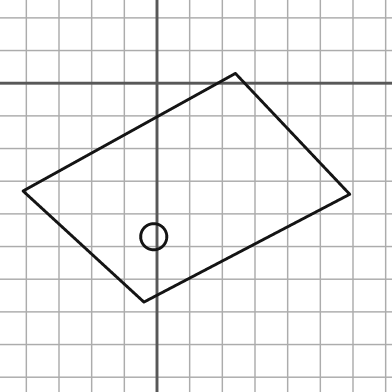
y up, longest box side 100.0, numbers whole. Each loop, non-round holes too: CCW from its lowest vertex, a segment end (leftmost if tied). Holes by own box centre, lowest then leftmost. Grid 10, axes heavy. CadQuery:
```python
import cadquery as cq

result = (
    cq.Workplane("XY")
    .moveTo(-4.0, -67.0)
    .lineTo(59.0, -34.0)
    .lineTo(24.0, 3.0)
    .lineTo(-41.0, -33.0)
    .close()
    .moveTo(-1.0, -47.0)
    .circle(4.0)
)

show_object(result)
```